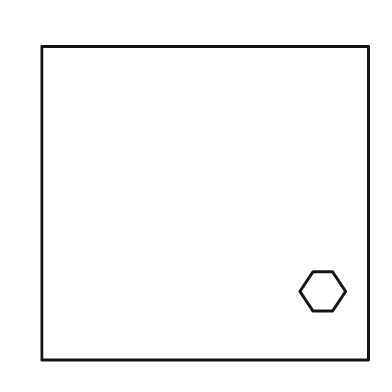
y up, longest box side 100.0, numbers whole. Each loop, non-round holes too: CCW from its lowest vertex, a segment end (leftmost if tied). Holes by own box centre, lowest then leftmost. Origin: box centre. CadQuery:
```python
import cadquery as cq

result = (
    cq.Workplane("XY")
    .moveTo(-50.0, -48.0)
    .lineTo(50.0, -48.0)
    .lineTo(50.0, 48.0)
    .lineTo(-50.0, 48.0)
    .close()
    .moveTo(33.0, -33.0)
    .lineTo(39.0, -33.0)
    .lineTo(43.0, -27.0)
    .lineTo(39.0, -21.0)
    .lineTo(33.0, -21.0)
    .lineTo(29.0, -27.0)
    .close()
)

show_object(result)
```